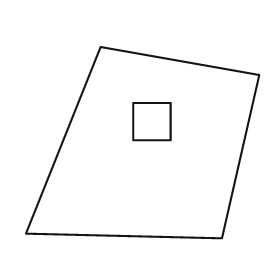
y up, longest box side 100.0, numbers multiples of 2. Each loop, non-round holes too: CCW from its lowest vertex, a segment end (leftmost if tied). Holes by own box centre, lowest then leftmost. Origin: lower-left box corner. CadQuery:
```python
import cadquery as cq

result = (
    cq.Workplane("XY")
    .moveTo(84.0, 0.0)
    .lineTo(100.0, 70.0)
    .lineTo(32.0, 82.0)
    .lineTo(0.0, 2.0)
    .close()
    .moveTo(46.0, 42.0)
    .lineTo(62.0, 42.0)
    .lineTo(62.0, 58.0)
    .lineTo(46.0, 58.0)
    .close()
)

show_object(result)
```